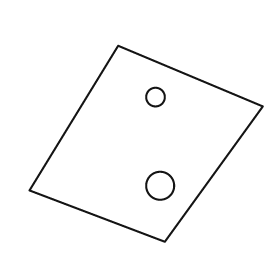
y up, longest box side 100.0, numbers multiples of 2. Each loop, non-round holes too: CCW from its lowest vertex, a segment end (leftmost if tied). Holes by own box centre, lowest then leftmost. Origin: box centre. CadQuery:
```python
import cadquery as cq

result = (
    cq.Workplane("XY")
    .moveTo(8.0, -42.0)
    .lineTo(50.0, 16.0)
    .lineTo(-12.0, 42.0)
    .lineTo(-50.0, -20.0)
    .close()
    .moveTo(6.0, -18.0)
    .circle(6.0)
    .moveTo(4.0, 20.0)
    .circle(4.0)
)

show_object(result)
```